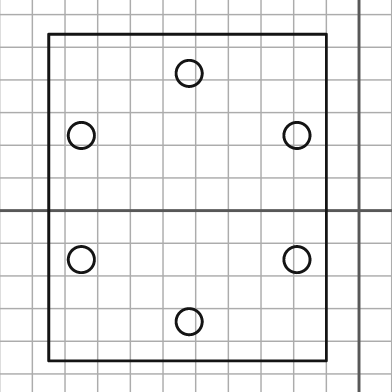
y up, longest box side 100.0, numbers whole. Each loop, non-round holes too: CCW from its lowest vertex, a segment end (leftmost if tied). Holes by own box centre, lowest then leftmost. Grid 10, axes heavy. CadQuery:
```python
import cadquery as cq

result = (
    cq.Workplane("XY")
    .moveTo(-95.0, -46.0)
    .lineTo(-10.0, -46.0)
    .lineTo(-10.0, 54.0)
    .lineTo(-95.0, 54.0)
    .close()
    .moveTo(-52.0, -34.0)
    .circle(4.0)
    .moveTo(-85.0, -15.0)
    .circle(4.0)
    .moveTo(-19.0, -15.0)
    .circle(4.0)
    .moveTo(-85.0, 23.0)
    .circle(4.0)
    .moveTo(-19.0, 23.0)
    .circle(4.0)
    .moveTo(-52.0, 42.0)
    .circle(4.0)
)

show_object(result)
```